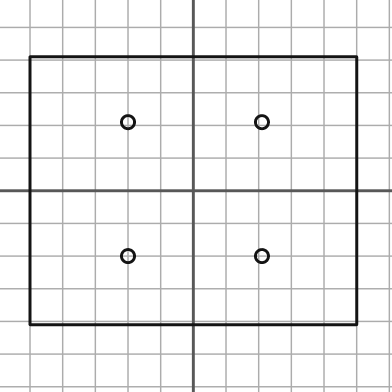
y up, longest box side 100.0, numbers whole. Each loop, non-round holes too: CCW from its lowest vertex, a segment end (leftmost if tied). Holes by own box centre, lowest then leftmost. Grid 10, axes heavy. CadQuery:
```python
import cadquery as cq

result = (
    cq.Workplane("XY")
    .moveTo(-50.0, -41.0)
    .lineTo(50.0, -41.0)
    .lineTo(50.0, 41.0)
    .lineTo(-50.0, 41.0)
    .close()
    .moveTo(-20.0, -20.0)
    .circle(2.0)
    .moveTo(21.0, -20.0)
    .circle(2.0)
    .moveTo(-20.0, 21.0)
    .circle(2.0)
    .moveTo(21.0, 21.0)
    .circle(2.0)
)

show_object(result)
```